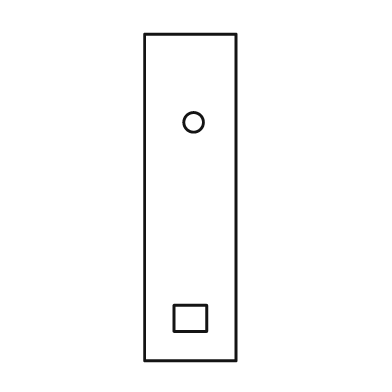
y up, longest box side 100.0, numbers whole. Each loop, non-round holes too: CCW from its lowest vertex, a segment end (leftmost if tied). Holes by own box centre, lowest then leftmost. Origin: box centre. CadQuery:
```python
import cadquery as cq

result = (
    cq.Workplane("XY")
    .moveTo(-14.0, -50.0)
    .lineTo(14.0, -50.0)
    .lineTo(14.0, 50.0)
    .lineTo(-14.0, 50.0)
    .close()
    .moveTo(-5.0, -41.0)
    .lineTo(5.0, -41.0)
    .lineTo(5.0, -33.0)
    .lineTo(-5.0, -33.0)
    .close()
    .moveTo(1.0, 23.0)
    .circle(3.0)
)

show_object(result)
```